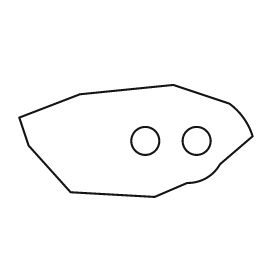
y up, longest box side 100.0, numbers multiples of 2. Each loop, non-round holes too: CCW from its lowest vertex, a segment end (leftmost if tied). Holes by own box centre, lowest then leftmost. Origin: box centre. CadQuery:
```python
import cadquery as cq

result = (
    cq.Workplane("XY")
    .moveTo(8.0, -24.0)
    .lineTo(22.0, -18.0)
    .threePointArc((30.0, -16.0), (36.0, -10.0))
    .lineTo(50.0, 2.0)
    .threePointArc((46.0, 10.0), (40.0, 16.0))
    .lineTo(16.0, 24.0)
    .lineTo(-24.0, 20.0)
    .lineTo(-50.0, 10.0)
    .lineTo(-46.0, -2.0)
    .lineTo(-28.0, -22.0)
    .close()
    .moveTo(4.0, 0.0)
    .circle(6.0)
    .moveTo(26.0, 0.0)
    .circle(6.0)
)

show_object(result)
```